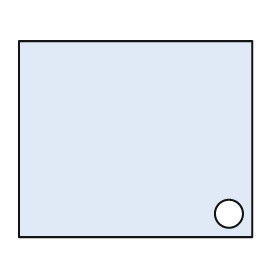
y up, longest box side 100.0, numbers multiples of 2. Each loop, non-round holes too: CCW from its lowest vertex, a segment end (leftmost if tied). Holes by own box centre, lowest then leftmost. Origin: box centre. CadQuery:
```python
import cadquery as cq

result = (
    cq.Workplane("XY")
    .moveTo(-50.0, -42.0)
    .lineTo(50.0, -42.0)
    .lineTo(50.0, 42.0)
    .lineTo(-50.0, 42.0)
    .close()
    .moveTo(40.0, -32.0)
    .circle(6.0)
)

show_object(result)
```